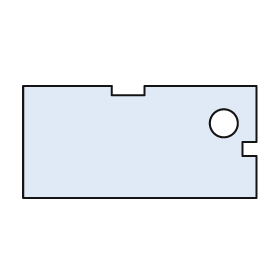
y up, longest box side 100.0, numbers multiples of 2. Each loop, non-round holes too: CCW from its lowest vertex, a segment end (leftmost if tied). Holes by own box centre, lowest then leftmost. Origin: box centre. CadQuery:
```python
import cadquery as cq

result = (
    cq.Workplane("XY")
    .moveTo(-50.0, -24.0)
    .lineTo(50.0, -24.0)
    .lineTo(50.0, -6.0)
    .lineTo(44.0, -6.0)
    .lineTo(44.0, 0.0)
    .lineTo(50.0, 0.0)
    .lineTo(50.0, 24.0)
    .lineTo(2.0, 24.0)
    .lineTo(2.0, 20.0)
    .lineTo(-12.0, 20.0)
    .lineTo(-12.0, 24.0)
    .lineTo(-50.0, 24.0)
    .close()
    .moveTo(36.0, 8.0)
    .circle(6.0)
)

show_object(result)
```